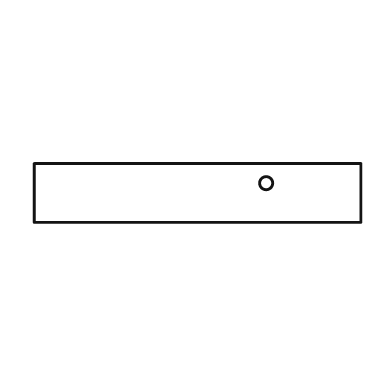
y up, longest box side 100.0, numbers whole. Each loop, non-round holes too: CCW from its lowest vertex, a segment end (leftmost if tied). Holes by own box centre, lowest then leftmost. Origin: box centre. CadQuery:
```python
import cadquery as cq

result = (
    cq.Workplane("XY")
    .moveTo(-50.0, -9.0)
    .lineTo(50.0, -9.0)
    .lineTo(50.0, 9.0)
    .lineTo(-50.0, 9.0)
    .close()
    .moveTo(21.0, 3.0)
    .circle(2.0)
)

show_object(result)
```